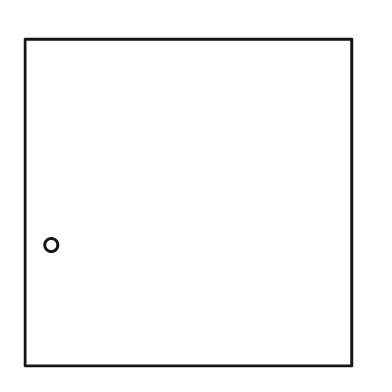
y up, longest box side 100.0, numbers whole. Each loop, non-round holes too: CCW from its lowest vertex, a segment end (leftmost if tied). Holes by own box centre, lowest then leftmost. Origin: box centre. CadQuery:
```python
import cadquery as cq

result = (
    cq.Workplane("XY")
    .moveTo(-50.0, -50.0)
    .lineTo(50.0, -50.0)
    .lineTo(50.0, 50.0)
    .lineTo(-50.0, 50.0)
    .close()
    .moveTo(-42.0, -13.0)
    .circle(2.0)
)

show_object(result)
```